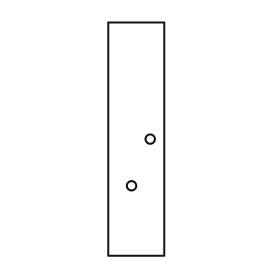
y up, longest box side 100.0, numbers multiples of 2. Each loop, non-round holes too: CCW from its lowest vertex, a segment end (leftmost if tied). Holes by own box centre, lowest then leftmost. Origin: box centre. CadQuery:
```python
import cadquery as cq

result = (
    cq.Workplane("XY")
    .moveTo(-12.0, -50.0)
    .lineTo(12.0, -50.0)
    .lineTo(12.0, 50.0)
    .lineTo(-12.0, 50.0)
    .close()
    .moveTo(-2.0, -20.0)
    .circle(2.0)
    .moveTo(6.0, 0.0)
    .circle(2.0)
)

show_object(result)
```